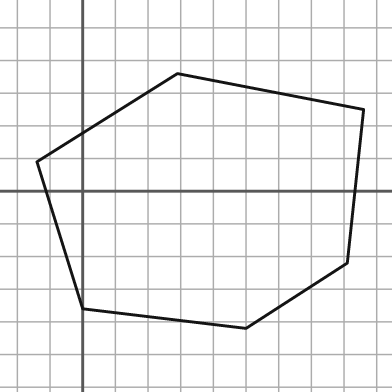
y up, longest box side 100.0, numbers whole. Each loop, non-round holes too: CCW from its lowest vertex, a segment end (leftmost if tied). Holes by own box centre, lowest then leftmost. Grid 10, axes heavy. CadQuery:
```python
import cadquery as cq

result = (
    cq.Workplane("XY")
    .moveTo(50.0, -42.0)
    .lineTo(81.0, -22.0)
    .lineTo(86.0, 25.0)
    .lineTo(29.0, 36.0)
    .lineTo(-14.0, 9.0)
    .lineTo(0.0, -36.0)
    .close()
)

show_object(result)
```